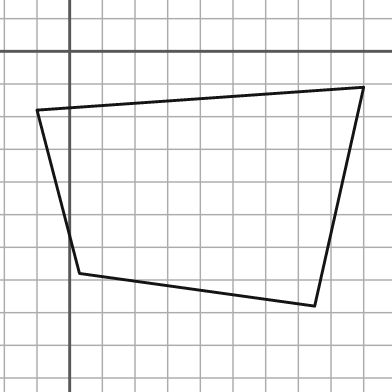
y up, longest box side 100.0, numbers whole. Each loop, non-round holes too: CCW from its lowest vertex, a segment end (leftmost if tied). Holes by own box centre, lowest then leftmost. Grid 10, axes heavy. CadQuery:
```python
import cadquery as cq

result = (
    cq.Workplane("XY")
    .moveTo(75.0, -78.0)
    .lineTo(90.0, -11.0)
    .lineTo(-10.0, -18.0)
    .lineTo(3.0, -68.0)
    .close()
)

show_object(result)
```